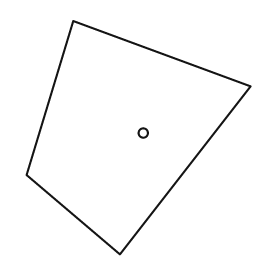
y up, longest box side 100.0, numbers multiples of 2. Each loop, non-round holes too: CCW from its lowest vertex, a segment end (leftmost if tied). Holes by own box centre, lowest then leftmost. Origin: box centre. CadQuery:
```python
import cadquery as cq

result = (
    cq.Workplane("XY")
    .moveTo(-8.0, -50.0)
    .lineTo(48.0, 22.0)
    .lineTo(-28.0, 50.0)
    .lineTo(-48.0, -16.0)
    .close()
    .moveTo(2.0, 2.0)
    .circle(2.0)
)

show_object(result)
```